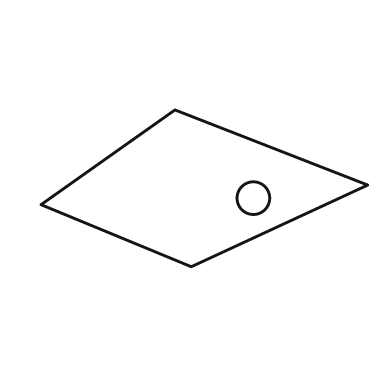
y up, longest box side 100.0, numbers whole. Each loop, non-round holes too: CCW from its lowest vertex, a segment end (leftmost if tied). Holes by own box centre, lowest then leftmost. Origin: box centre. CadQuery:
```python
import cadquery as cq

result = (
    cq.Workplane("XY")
    .moveTo(-4.0, -24.0)
    .lineTo(50.0, 1.0)
    .lineTo(-9.0, 24.0)
    .lineTo(-50.0, -5.0)
    .close()
    .moveTo(15.0, -3.0)
    .circle(5.0)
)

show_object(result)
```